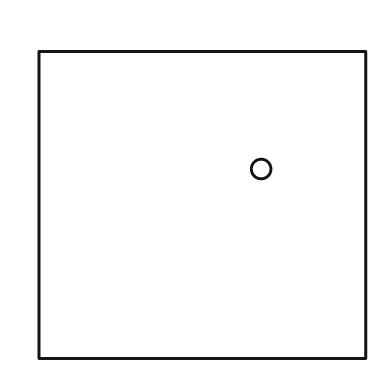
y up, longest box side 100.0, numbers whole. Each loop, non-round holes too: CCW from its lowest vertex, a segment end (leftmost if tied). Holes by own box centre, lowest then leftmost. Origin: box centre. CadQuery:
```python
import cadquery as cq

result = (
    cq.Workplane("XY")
    .moveTo(-50.0, -47.0)
    .lineTo(50.0, -47.0)
    .lineTo(50.0, 47.0)
    .lineTo(-50.0, 47.0)
    .close()
    .moveTo(18.0, 11.0)
    .circle(3.0)
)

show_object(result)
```